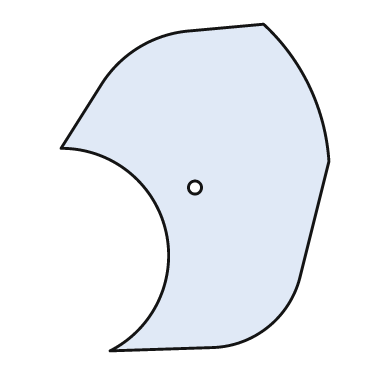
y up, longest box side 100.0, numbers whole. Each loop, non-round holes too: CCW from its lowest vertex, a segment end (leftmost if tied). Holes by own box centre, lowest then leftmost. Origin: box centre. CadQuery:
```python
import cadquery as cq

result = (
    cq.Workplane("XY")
    .moveTo(-26.0, -50.0)
    .lineTo(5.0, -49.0)
    .threePointArc((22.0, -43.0), (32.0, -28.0))
    .lineTo(41.0, 8.0)
    .threePointArc((35.0, 31.0), (21.0, 50.0))
    .lineTo(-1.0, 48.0)
    .threePointArc((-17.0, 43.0), (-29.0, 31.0))
    .lineTo(-41.0, 12.0)
    .threePointArc((-9.0, -13.0), (-26.0, -50.0))
    .close()
    .moveTo(0.0, 0.0)
    .circle(2.0)
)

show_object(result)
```